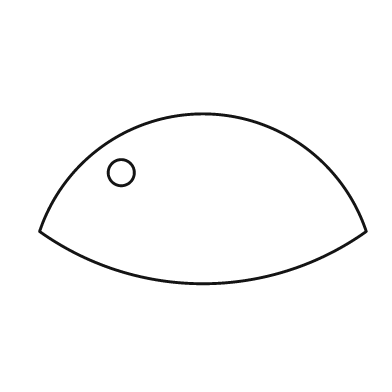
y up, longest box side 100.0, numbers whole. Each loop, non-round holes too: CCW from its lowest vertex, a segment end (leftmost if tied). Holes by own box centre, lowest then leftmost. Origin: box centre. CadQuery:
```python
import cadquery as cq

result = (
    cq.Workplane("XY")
    .moveTo(-50.0, -10.0)
    .threePointArc((0.0, -26.0), (50.0, -10.0))
    .threePointArc((0.0, 26.0), (-50.0, -10.0))
    .close()
    .moveTo(-25.0, 8.0)
    .circle(4.0)
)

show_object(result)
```